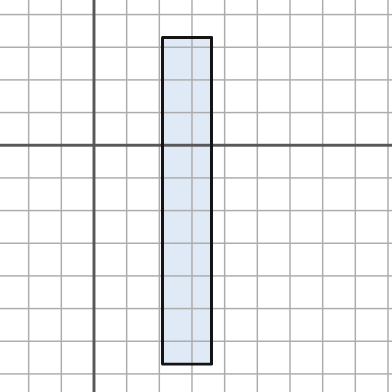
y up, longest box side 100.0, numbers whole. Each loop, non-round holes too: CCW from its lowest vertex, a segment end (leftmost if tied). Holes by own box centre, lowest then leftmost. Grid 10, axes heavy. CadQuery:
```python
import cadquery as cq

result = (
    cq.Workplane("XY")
    .moveTo(21.0, -67.0)
    .lineTo(36.0, -67.0)
    .lineTo(36.0, 33.0)
    .lineTo(21.0, 33.0)
    .close()
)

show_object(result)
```